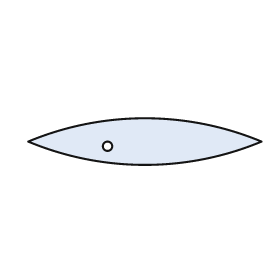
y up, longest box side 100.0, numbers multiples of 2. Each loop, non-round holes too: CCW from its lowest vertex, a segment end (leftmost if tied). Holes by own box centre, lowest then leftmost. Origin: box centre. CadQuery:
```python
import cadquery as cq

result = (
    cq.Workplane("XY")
    .moveTo(-50.0, 0.0)
    .threePointArc((0.0, -10.0), (50.0, 0.0))
    .threePointArc((0.0, 10.0), (-50.0, 0.0))
    .close()
    .moveTo(-16.0, -2.0)
    .circle(2.0)
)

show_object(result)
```